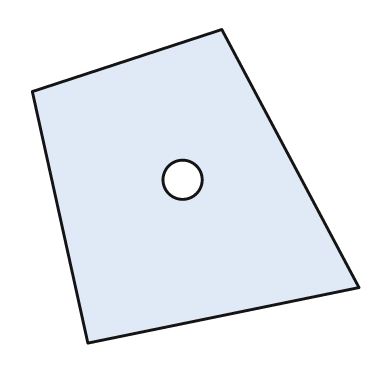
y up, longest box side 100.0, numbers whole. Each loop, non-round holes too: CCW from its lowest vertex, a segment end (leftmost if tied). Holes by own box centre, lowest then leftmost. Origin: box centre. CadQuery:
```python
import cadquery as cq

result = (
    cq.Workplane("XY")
    .moveTo(-33.0, -48.0)
    .lineTo(50.0, -31.0)
    .lineTo(8.0, 48.0)
    .lineTo(-50.0, 29.0)
    .close()
    .moveTo(-4.0, 2.0)
    .circle(6.0)
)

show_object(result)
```